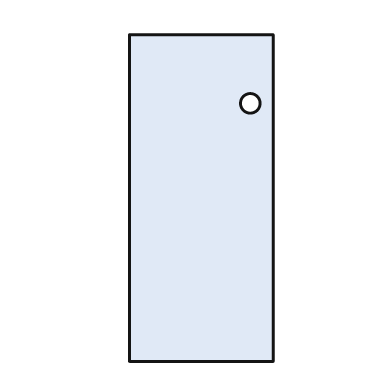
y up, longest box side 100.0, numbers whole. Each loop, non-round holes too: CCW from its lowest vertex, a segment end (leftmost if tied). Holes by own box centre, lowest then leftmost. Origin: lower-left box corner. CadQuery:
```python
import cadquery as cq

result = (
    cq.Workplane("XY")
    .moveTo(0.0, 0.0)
    .lineTo(44.0, 0.0)
    .lineTo(44.0, 100.0)
    .lineTo(0.0, 100.0)
    .close()
    .moveTo(37.0, 79.0)
    .circle(3.0)
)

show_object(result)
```